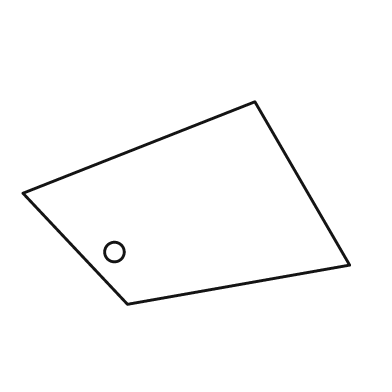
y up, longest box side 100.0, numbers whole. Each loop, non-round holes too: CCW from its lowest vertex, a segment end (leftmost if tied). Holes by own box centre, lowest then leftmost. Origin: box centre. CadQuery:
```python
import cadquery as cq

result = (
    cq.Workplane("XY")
    .moveTo(-18.0, -31.0)
    .lineTo(50.0, -19.0)
    .lineTo(21.0, 31.0)
    .lineTo(-50.0, 3.0)
    .close()
    .moveTo(-22.0, -15.0)
    .circle(3.0)
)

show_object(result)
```